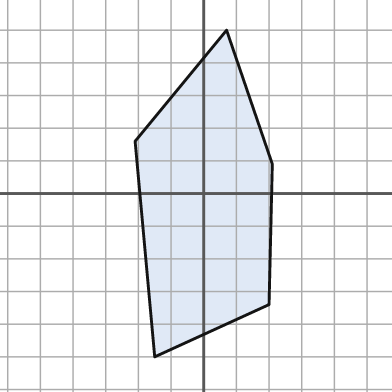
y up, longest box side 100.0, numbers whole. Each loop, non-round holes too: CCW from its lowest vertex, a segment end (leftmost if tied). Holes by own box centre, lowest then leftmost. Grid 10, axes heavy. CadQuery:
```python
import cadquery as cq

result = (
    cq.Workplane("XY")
    .moveTo(-15.0, -50.0)
    .lineTo(20.0, -34.0)
    .lineTo(21.0, 9.0)
    .lineTo(7.0, 50.0)
    .lineTo(-21.0, 16.0)
    .close()
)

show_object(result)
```